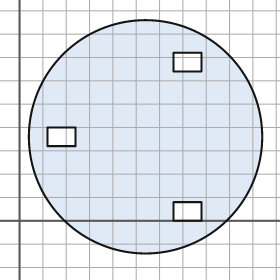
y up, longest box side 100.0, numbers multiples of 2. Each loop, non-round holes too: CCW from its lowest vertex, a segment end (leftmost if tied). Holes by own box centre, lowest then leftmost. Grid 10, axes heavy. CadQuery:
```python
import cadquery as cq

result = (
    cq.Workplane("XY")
    .moveTo(54.0, 36.0)
    .circle(50.0)
    .moveTo(66.0, 0.0)
    .lineTo(78.0, 0.0)
    .lineTo(78.0, 8.0)
    .lineTo(66.0, 8.0)
    .close()
    .moveTo(12.0, 32.0)
    .lineTo(24.0, 32.0)
    .lineTo(24.0, 40.0)
    .lineTo(12.0, 40.0)
    .close()
    .moveTo(66.0, 64.0)
    .lineTo(78.0, 64.0)
    .lineTo(78.0, 72.0)
    .lineTo(66.0, 72.0)
    .close()
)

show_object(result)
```